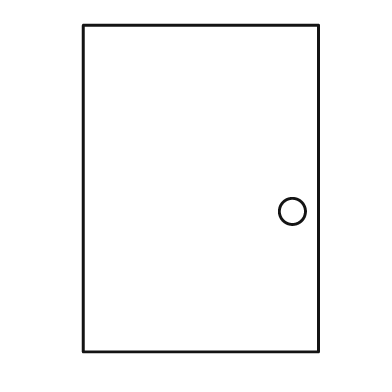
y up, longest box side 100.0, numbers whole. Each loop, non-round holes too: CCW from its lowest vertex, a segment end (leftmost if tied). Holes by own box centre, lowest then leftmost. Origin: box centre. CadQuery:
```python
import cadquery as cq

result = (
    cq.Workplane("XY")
    .moveTo(-36.0, -50.0)
    .lineTo(36.0, -50.0)
    .lineTo(36.0, 50.0)
    .lineTo(-36.0, 50.0)
    .close()
    .moveTo(28.0, -7.0)
    .circle(4.0)
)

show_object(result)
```